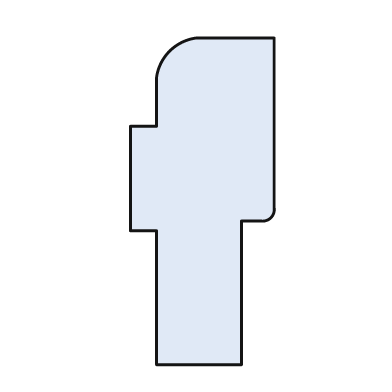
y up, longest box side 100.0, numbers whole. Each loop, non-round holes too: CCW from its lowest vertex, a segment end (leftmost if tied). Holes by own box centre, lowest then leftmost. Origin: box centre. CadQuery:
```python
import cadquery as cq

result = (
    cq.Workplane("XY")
    .moveTo(-14.0, -50.0)
    .lineTo(12.0, -50.0)
    .lineTo(12.0, -6.0)
    .lineTo(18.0, -6.0)
    .threePointArc((21.0, -5.0), (22.0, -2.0))
    .lineTo(22.0, 50.0)
    .lineTo(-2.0, 50.0)
    .threePointArc((-10.0, 46.0), (-14.0, 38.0))
    .lineTo(-14.0, 23.0)
    .lineTo(-22.0, 23.0)
    .lineTo(-22.0, -9.0)
    .lineTo(-14.0, -9.0)
    .close()
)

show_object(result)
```